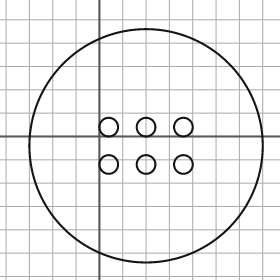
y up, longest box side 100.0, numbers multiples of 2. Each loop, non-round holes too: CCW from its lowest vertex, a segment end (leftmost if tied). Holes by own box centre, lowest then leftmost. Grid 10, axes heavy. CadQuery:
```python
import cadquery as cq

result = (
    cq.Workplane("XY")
    .moveTo(20.0, -4.0)
    .circle(50.0)
    .moveTo(4.0, -12.0)
    .circle(4.0)
    .moveTo(20.0, -12.0)
    .circle(4.0)
    .moveTo(36.0, -12.0)
    .circle(4.0)
    .moveTo(4.0, 4.0)
    .circle(4.0)
    .moveTo(20.0, 4.0)
    .circle(4.0)
    .moveTo(36.0, 4.0)
    .circle(4.0)
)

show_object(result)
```